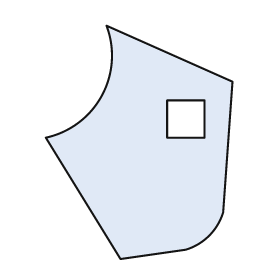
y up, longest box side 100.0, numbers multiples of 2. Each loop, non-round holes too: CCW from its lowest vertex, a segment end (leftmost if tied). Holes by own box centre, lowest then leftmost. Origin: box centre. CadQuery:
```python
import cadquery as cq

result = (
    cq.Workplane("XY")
    .moveTo(-8.0, -50.0)
    .lineTo(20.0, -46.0)
    .threePointArc((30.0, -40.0), (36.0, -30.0))
    .lineTo(40.0, 26.0)
    .lineTo(-14.0, 50.0)
    .threePointArc((-16.0, 20.0), (-40.0, 2.0))
    .close()
    .moveTo(12.0, 2.0)
    .lineTo(28.0, 2.0)
    .lineTo(28.0, 18.0)
    .lineTo(12.0, 18.0)
    .close()
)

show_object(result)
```